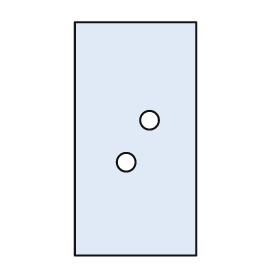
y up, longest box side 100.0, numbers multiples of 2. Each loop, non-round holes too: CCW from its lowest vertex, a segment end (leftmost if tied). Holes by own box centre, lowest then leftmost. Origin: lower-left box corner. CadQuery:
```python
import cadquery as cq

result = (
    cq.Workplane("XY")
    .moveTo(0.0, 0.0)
    .lineTo(52.0, 0.0)
    .lineTo(52.0, 100.0)
    .lineTo(0.0, 100.0)
    .close()
    .moveTo(22.0, 40.0)
    .circle(4.0)
    .moveTo(32.0, 58.0)
    .circle(4.0)
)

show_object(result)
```